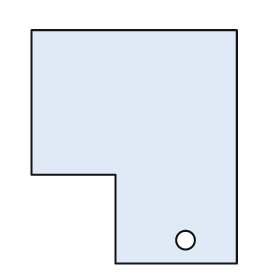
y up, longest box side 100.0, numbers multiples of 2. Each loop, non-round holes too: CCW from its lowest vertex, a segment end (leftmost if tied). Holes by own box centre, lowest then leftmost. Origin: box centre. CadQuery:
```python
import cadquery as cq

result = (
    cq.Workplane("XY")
    .moveTo(-8.0, -50.0)
    .lineTo(44.0, -50.0)
    .lineTo(44.0, 50.0)
    .lineTo(-44.0, 50.0)
    .lineTo(-44.0, -12.0)
    .lineTo(-8.0, -12.0)
    .close()
    .moveTo(22.0, -40.0)
    .circle(4.0)
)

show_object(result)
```